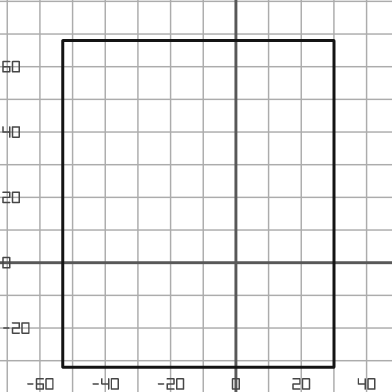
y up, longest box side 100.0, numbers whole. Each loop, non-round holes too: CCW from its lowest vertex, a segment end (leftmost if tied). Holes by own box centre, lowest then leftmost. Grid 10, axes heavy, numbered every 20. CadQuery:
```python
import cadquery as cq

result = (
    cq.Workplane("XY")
    .moveTo(-53.0, -32.0)
    .lineTo(30.0, -32.0)
    .lineTo(30.0, 68.0)
    .lineTo(-53.0, 68.0)
    .close()
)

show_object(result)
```